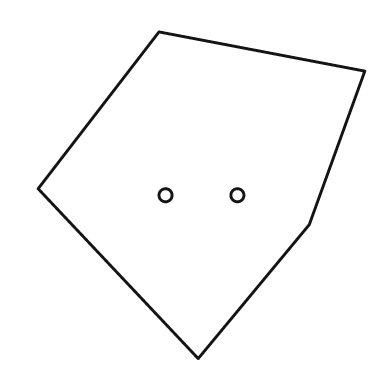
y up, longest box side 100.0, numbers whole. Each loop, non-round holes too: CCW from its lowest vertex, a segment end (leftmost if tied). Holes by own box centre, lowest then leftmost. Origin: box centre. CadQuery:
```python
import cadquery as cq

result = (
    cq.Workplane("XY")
    .moveTo(-1.0, -50.0)
    .lineTo(33.0, -9.0)
    .lineTo(50.0, 38.0)
    .lineTo(-13.0, 50.0)
    .lineTo(-50.0, 2.0)
    .close()
    .moveTo(-11.0, 0.0)
    .circle(2.0)
    .moveTo(11.0, 0.0)
    .circle(2.0)
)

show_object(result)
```